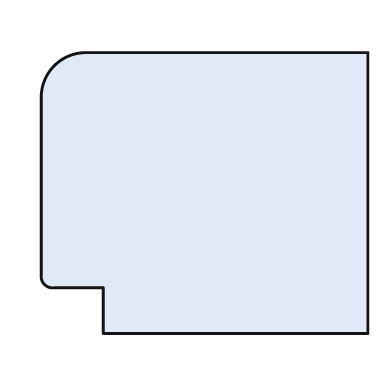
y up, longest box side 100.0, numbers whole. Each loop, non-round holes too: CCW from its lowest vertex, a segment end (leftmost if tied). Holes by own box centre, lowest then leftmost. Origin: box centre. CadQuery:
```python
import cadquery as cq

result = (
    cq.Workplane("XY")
    .moveTo(-31.0, -43.0)
    .lineTo(50.0, -43.0)
    .lineTo(50.0, 43.0)
    .lineTo(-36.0, 43.0)
    .threePointArc((-46.0, 39.0), (-50.0, 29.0))
    .lineTo(-50.0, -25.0)
    .threePointArc((-49.0, -28.0), (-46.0, -29.0))
    .lineTo(-31.0, -29.0)
    .close()
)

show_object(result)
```